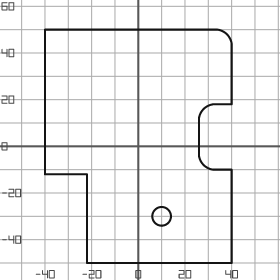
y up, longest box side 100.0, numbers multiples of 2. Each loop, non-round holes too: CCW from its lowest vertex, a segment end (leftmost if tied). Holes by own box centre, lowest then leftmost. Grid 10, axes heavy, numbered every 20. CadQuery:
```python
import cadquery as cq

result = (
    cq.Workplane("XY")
    .moveTo(-22.0, -50.0)
    .lineTo(40.0, -50.0)
    .lineTo(40.0, -10.0)
    .lineTo(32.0, -10.0)
    .threePointArc((28.0, -8.0), (26.0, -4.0))
    .lineTo(26.0, 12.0)
    .threePointArc((28.0, 16.0), (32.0, 18.0))
    .lineTo(40.0, 18.0)
    .lineTo(40.0, 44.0)
    .threePointArc((38.0, 48.0), (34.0, 50.0))
    .lineTo(-40.0, 50.0)
    .lineTo(-40.0, -12.0)
    .lineTo(-22.0, -12.0)
    .close()
    .moveTo(10.0, -30.0)
    .circle(4.0)
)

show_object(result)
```